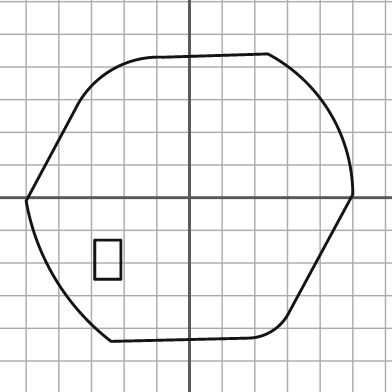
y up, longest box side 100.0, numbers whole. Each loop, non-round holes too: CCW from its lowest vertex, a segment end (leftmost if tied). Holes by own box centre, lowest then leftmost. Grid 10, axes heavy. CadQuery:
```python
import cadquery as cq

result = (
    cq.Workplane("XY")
    .moveTo(-24.0, -44.0)
    .lineTo(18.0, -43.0)
    .threePointArc((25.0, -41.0), (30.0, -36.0))
    .lineTo(50.0, 1.0)
    .threePointArc((43.0, 26.0), (24.0, 44.0))
    .lineTo(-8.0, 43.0)
    .threePointArc((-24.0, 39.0), (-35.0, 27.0))
    .lineTo(-50.0, -1.0)
    .threePointArc((-41.0, -25.0), (-24.0, -44.0))
    .close()
    .moveTo(-29.0, -25.0)
    .lineTo(-21.0, -25.0)
    .lineTo(-21.0, -13.0)
    .lineTo(-29.0, -13.0)
    .close()
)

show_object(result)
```